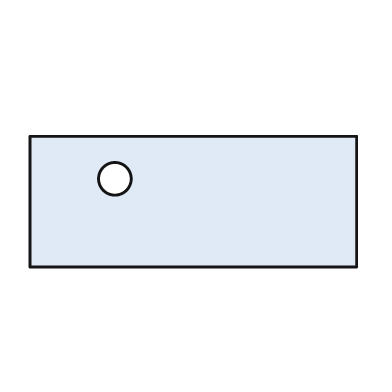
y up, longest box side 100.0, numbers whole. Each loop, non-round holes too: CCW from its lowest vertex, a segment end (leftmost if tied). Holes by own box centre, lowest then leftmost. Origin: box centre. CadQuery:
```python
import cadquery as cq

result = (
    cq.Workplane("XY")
    .moveTo(-50.0, -20.0)
    .lineTo(50.0, -20.0)
    .lineTo(50.0, 20.0)
    .lineTo(-50.0, 20.0)
    .close()
    .moveTo(-24.0, 7.0)
    .circle(5.0)
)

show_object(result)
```